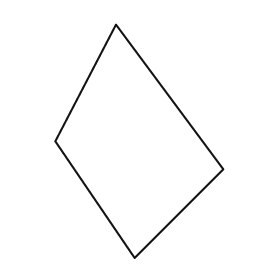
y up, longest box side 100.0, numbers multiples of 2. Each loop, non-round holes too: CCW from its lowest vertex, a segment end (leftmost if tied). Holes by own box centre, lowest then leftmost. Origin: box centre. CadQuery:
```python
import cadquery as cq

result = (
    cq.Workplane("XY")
    .moveTo(-2.0, -50.0)
    .lineTo(36.0, -12.0)
    .lineTo(-10.0, 50.0)
    .lineTo(-36.0, 0.0)
    .close()
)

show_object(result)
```